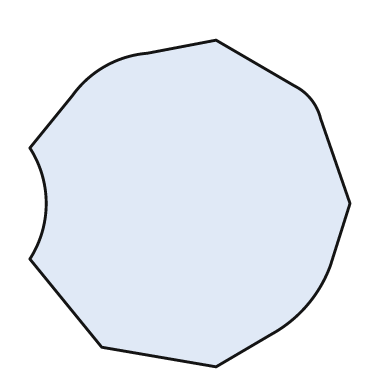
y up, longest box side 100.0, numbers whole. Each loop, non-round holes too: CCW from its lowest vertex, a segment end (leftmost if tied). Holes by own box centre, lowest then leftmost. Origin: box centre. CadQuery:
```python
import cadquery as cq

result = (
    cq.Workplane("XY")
    .moveTo(8.0, -50.0)
    .lineTo(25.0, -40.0)
    .threePointArc((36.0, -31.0), (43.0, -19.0))
    .lineTo(49.0, 0.0)
    .lineTo(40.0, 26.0)
    .threePointArc((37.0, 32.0), (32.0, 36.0))
    .lineTo(8.0, 50.0)
    .lineTo(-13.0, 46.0)
    .threePointArc((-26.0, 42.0), (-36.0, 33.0))
    .lineTo(-49.0, 17.0)
    .threePointArc((-44.0, 0.0), (-49.0, -17.0))
    .lineTo(-27.0, -44.0)
    .close()
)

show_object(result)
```